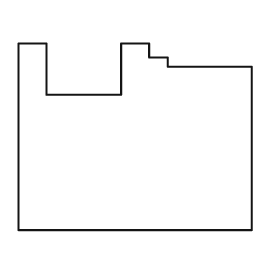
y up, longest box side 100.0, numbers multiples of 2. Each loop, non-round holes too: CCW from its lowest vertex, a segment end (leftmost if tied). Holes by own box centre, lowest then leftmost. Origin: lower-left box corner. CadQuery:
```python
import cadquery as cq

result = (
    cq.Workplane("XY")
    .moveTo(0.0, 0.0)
    .lineTo(100.0, 0.0)
    .lineTo(100.0, 70.0)
    .lineTo(64.0, 70.0)
    .lineTo(64.0, 74.0)
    .lineTo(56.0, 74.0)
    .lineTo(56.0, 80.0)
    .lineTo(44.0, 80.0)
    .lineTo(44.0, 58.0)
    .lineTo(12.0, 58.0)
    .lineTo(12.0, 80.0)
    .lineTo(0.0, 80.0)
    .close()
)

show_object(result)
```